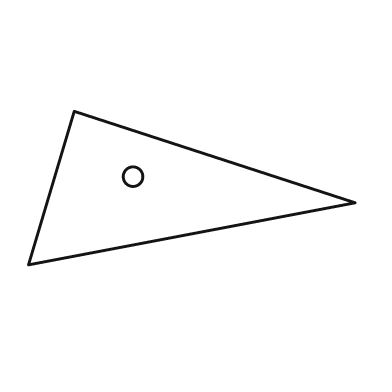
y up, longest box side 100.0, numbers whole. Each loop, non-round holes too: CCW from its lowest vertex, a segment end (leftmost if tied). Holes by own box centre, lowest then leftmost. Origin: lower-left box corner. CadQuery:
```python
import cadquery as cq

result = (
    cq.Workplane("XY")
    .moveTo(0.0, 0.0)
    .lineTo(100.0, 19.0)
    .lineTo(14.0, 47.0)
    .close()
    .moveTo(32.0, 27.0)
    .circle(3.0)
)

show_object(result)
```